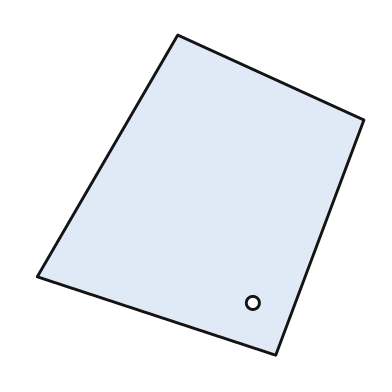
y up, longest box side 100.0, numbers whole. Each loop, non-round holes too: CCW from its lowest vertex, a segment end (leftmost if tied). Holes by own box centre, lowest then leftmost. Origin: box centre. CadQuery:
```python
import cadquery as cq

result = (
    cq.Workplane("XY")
    .moveTo(23.0, -49.0)
    .lineTo(50.0, 23.0)
    .lineTo(-7.0, 49.0)
    .lineTo(-50.0, -25.0)
    .close()
    .moveTo(16.0, -33.0)
    .circle(2.0)
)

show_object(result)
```